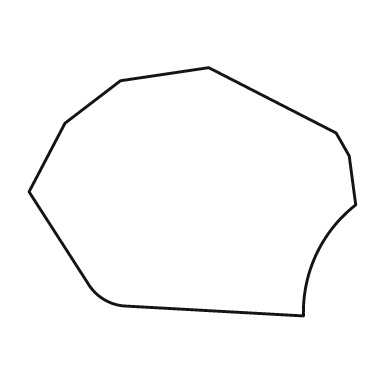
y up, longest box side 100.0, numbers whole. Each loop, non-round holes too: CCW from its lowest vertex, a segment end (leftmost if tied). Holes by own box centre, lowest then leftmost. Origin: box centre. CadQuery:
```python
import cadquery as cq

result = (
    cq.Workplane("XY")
    .moveTo(34.0, -38.0)
    .threePointArc((38.0, -19.0), (50.0, -4.0))
    .lineTo(48.0, 11.0)
    .lineTo(44.0, 18.0)
    .lineTo(5.0, 38.0)
    .lineTo(-22.0, 34.0)
    .lineTo(-39.0, 21.0)
    .lineTo(-50.0, 0.0)
    .lineTo(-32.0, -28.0)
    .threePointArc((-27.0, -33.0), (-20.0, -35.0))
    .close()
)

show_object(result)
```